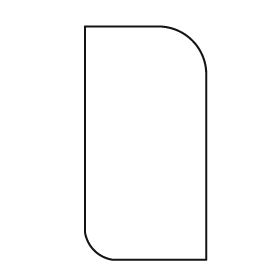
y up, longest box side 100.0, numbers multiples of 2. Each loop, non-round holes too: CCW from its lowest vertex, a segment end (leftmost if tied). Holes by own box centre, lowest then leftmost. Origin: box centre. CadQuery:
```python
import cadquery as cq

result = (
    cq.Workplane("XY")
    .moveTo(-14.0, -50.0)
    .lineTo(26.0, -50.0)
    .lineTo(26.0, 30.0)
    .threePointArc((20.0, 44.0), (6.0, 50.0))
    .lineTo(-26.0, 50.0)
    .lineTo(-26.0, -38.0)
    .threePointArc((-22.0, -46.0), (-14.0, -50.0))
    .close()
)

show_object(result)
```